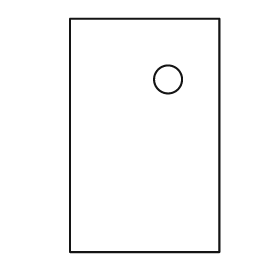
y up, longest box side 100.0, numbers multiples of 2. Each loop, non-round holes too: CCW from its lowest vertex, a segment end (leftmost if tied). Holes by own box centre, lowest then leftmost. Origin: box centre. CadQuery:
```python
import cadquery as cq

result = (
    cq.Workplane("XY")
    .moveTo(-32.0, -50.0)
    .lineTo(32.0, -50.0)
    .lineTo(32.0, 50.0)
    .lineTo(-32.0, 50.0)
    .close()
    .moveTo(10.0, 24.0)
    .circle(6.0)
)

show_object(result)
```